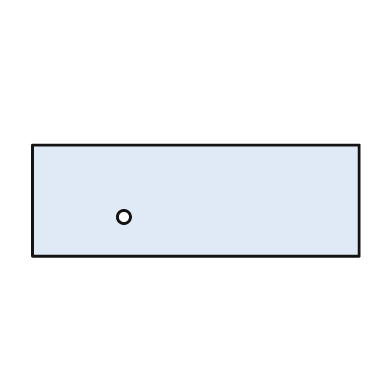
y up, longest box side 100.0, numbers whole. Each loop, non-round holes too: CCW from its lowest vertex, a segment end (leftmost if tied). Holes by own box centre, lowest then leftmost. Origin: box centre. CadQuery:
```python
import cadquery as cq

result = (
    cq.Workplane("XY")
    .moveTo(-50.0, -17.0)
    .lineTo(50.0, -17.0)
    .lineTo(50.0, 17.0)
    .lineTo(-50.0, 17.0)
    .close()
    .moveTo(-22.0, -5.0)
    .circle(2.0)
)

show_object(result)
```